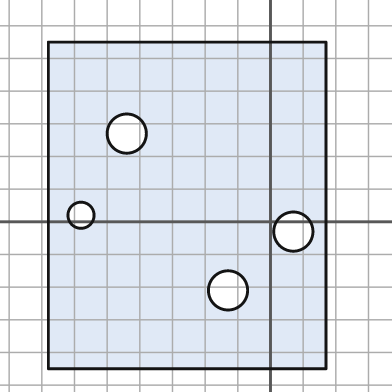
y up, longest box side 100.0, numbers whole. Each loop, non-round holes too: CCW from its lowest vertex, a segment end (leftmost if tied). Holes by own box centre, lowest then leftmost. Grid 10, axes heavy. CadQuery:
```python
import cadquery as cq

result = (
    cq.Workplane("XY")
    .moveTo(-68.0, -45.0)
    .lineTo(17.0, -45.0)
    .lineTo(17.0, 55.0)
    .lineTo(-68.0, 55.0)
    .close()
    .moveTo(-13.0, -21.0)
    .circle(6.0)
    .moveTo(7.0, -3.0)
    .circle(6.0)
    .moveTo(-58.0, 2.0)
    .circle(4.0)
    .moveTo(-44.0, 27.0)
    .circle(6.0)
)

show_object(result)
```